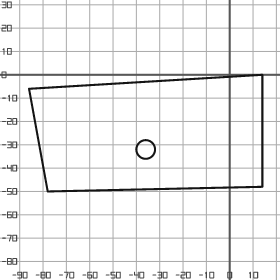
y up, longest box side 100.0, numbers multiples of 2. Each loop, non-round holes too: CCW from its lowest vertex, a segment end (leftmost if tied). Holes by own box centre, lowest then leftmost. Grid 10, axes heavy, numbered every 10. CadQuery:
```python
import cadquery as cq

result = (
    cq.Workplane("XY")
    .moveTo(-78.0, -50.0)
    .lineTo(14.0, -48.0)
    .lineTo(14.0, 0.0)
    .lineTo(-86.0, -6.0)
    .close()
    .moveTo(-36.0, -32.0)
    .circle(4.0)
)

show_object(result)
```